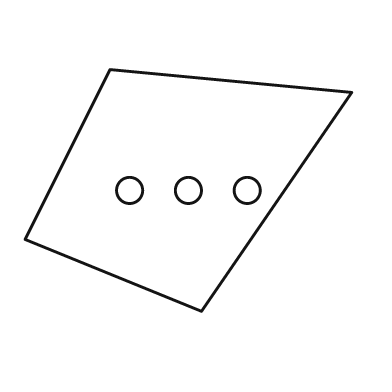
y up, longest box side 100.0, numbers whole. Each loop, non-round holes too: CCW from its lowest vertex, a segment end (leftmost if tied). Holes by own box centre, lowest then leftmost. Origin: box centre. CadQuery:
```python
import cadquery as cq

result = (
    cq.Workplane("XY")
    .moveTo(4.0, -37.0)
    .lineTo(50.0, 30.0)
    .lineTo(-24.0, 37.0)
    .lineTo(-50.0, -15.0)
    .close()
    .moveTo(-18.0, 0.0)
    .circle(4.0)
    .moveTo(0.0, 0.0)
    .circle(4.0)
    .moveTo(18.0, 0.0)
    .circle(4.0)
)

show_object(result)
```